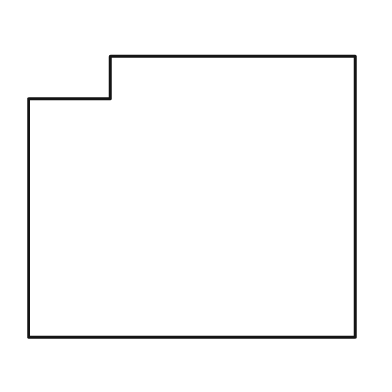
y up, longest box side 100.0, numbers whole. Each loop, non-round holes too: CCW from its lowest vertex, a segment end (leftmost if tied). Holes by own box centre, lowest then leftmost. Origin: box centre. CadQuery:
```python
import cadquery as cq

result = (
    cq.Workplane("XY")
    .moveTo(-50.0, -43.0)
    .lineTo(50.0, -43.0)
    .lineTo(50.0, 43.0)
    .lineTo(-25.0, 43.0)
    .lineTo(-25.0, 30.0)
    .lineTo(-50.0, 30.0)
    .close()
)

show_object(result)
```